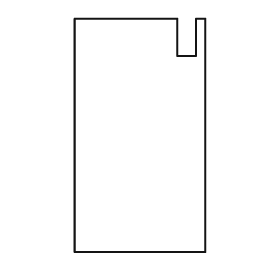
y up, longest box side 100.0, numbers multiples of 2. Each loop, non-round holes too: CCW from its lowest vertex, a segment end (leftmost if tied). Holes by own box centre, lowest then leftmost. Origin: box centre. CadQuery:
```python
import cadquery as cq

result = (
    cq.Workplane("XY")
    .moveTo(-28.0, -50.0)
    .lineTo(28.0, -50.0)
    .lineTo(28.0, 50.0)
    .lineTo(24.0, 50.0)
    .lineTo(24.0, 34.0)
    .lineTo(16.0, 34.0)
    .lineTo(16.0, 50.0)
    .lineTo(-28.0, 50.0)
    .close()
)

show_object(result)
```